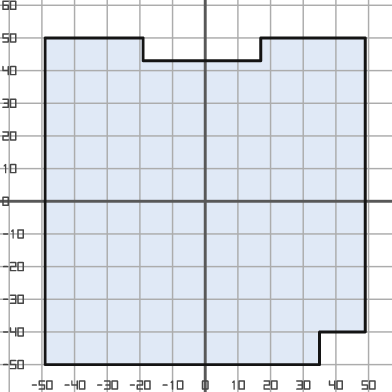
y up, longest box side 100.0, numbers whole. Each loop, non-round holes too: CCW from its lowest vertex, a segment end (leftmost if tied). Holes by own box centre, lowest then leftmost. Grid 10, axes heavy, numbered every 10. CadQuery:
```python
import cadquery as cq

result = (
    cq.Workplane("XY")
    .moveTo(-49.0, -50.0)
    .lineTo(35.0, -50.0)
    .lineTo(35.0, -40.0)
    .lineTo(49.0, -40.0)
    .lineTo(49.0, 50.0)
    .lineTo(17.0, 50.0)
    .lineTo(17.0, 43.0)
    .lineTo(-19.0, 43.0)
    .lineTo(-19.0, 50.0)
    .lineTo(-49.0, 50.0)
    .close()
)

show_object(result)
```